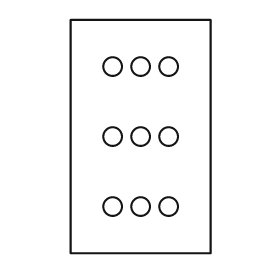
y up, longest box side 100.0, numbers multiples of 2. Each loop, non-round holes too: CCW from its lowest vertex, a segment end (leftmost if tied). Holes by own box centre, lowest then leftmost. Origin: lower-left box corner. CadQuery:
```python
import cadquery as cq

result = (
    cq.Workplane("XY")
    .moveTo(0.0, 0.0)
    .lineTo(60.0, 0.0)
    .lineTo(60.0, 100.0)
    .lineTo(0.0, 100.0)
    .close()
    .moveTo(18.0, 20.0)
    .circle(4.0)
    .moveTo(30.0, 20.0)
    .circle(4.0)
    .moveTo(42.0, 20.0)
    .circle(4.0)
    .moveTo(18.0, 50.0)
    .circle(4.0)
    .moveTo(30.0, 50.0)
    .circle(4.0)
    .moveTo(42.0, 50.0)
    .circle(4.0)
    .moveTo(18.0, 80.0)
    .circle(4.0)
    .moveTo(30.0, 80.0)
    .circle(4.0)
    .moveTo(42.0, 80.0)
    .circle(4.0)
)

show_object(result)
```